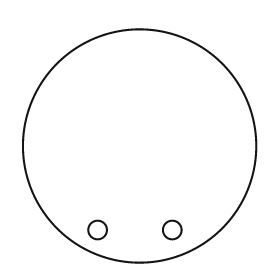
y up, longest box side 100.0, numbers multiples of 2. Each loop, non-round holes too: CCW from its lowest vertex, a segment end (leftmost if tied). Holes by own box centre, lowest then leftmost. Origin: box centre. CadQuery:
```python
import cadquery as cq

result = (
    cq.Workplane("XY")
    .moveTo(0.0, 0.0)
    .circle(50.0)
    .moveTo(-18.0, -36.0)
    .circle(4.0)
    .moveTo(14.0, -36.0)
    .circle(4.0)
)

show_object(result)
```